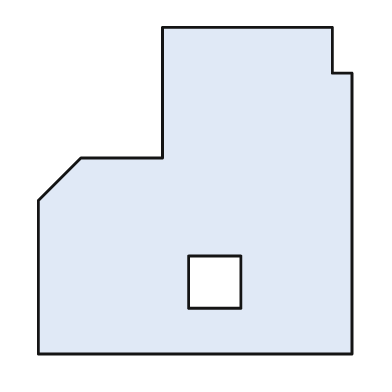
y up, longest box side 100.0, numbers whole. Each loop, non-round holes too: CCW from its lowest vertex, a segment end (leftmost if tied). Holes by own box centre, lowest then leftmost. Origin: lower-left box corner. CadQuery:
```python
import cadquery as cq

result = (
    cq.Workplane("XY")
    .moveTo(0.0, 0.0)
    .lineTo(96.0, 0.0)
    .lineTo(96.0, 86.0)
    .lineTo(90.0, 86.0)
    .lineTo(90.0, 100.0)
    .lineTo(38.0, 100.0)
    .lineTo(38.0, 60.0)
    .lineTo(13.0, 60.0)
    .lineTo(0.0, 47.0)
    .close()
    .moveTo(46.0, 14.0)
    .lineTo(62.0, 14.0)
    .lineTo(62.0, 30.0)
    .lineTo(46.0, 30.0)
    .close()
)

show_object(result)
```